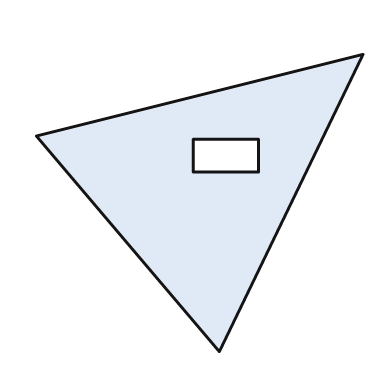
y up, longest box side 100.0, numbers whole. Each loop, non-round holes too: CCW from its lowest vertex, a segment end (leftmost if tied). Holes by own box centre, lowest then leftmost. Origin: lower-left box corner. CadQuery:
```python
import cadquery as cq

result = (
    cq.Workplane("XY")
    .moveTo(56.0, 0.0)
    .lineTo(100.0, 91.0)
    .lineTo(0.0, 66.0)
    .close()
    .moveTo(48.0, 55.0)
    .lineTo(68.0, 55.0)
    .lineTo(68.0, 65.0)
    .lineTo(48.0, 65.0)
    .close()
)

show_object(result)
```